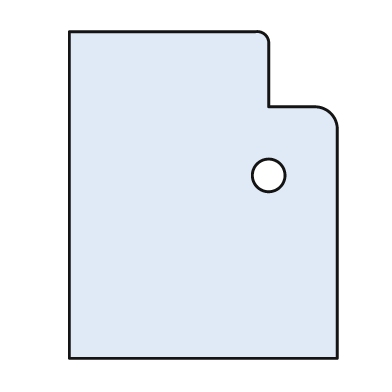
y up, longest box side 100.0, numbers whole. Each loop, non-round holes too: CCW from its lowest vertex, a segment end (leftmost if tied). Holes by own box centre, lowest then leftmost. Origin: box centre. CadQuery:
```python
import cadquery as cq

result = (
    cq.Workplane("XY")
    .moveTo(-41.0, -50.0)
    .lineTo(41.0, -50.0)
    .lineTo(41.0, 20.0)
    .threePointArc((39.0, 25.0), (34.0, 27.0))
    .lineTo(20.0, 27.0)
    .lineTo(20.0, 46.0)
    .threePointArc((19.0, 49.0), (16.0, 50.0))
    .lineTo(-41.0, 50.0)
    .close()
    .moveTo(20.0, 6.0)
    .circle(5.0)
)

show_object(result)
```